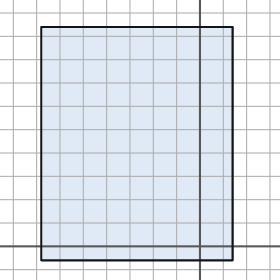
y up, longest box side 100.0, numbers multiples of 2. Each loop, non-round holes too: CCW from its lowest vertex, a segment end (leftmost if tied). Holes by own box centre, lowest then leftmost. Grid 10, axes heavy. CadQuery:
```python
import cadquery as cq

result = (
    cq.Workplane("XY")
    .moveTo(-68.0, -6.0)
    .lineTo(14.0, -6.0)
    .lineTo(14.0, 94.0)
    .lineTo(-68.0, 94.0)
    .close()
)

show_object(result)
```